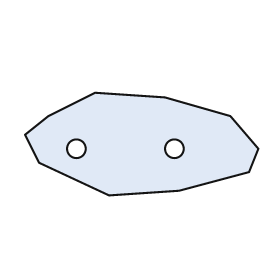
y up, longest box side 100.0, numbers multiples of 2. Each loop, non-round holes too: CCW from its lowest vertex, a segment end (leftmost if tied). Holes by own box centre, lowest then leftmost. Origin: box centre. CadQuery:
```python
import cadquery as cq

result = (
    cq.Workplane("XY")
    .moveTo(-14.0, -22.0)
    .lineTo(16.0, -20.0)
    .lineTo(46.0, -12.0)
    .lineTo(50.0, -2.0)
    .lineTo(38.0, 12.0)
    .lineTo(10.0, 20.0)
    .lineTo(-20.0, 22.0)
    .lineTo(-40.0, 12.0)
    .lineTo(-50.0, 4.0)
    .lineTo(-44.0, -8.0)
    .close()
    .moveTo(-28.0, -2.0)
    .circle(4.0)
    .moveTo(14.0, -2.0)
    .circle(4.0)
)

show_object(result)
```